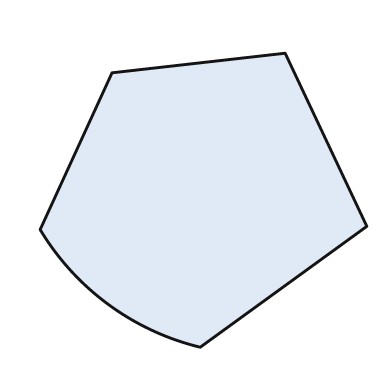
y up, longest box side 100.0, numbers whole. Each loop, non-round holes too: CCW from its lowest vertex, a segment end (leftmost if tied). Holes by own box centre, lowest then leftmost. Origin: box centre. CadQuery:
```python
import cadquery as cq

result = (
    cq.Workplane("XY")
    .moveTo(-1.0, -45.0)
    .lineTo(50.0, -8.0)
    .lineTo(25.0, 45.0)
    .lineTo(-28.0, 39.0)
    .lineTo(-50.0, -9.0)
    .threePointArc((-29.0, -32.0), (-1.0, -45.0))
    .close()
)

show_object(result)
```